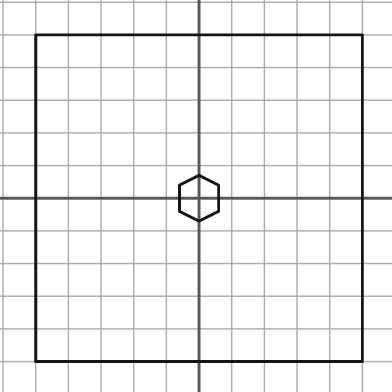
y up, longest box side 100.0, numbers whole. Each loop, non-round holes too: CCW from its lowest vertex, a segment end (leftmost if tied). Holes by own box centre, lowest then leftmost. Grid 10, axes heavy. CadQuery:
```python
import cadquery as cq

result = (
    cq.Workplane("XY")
    .moveTo(-50.0, -50.0)
    .lineTo(50.0, -50.0)
    .lineTo(50.0, 50.0)
    .lineTo(-50.0, 50.0)
    .close()
    .moveTo(0.0, -7.0)
    .lineTo(6.0, -4.0)
    .lineTo(6.0, 4.0)
    .lineTo(0.0, 7.0)
    .lineTo(-6.0, 4.0)
    .lineTo(-6.0, -4.0)
    .close()
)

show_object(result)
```